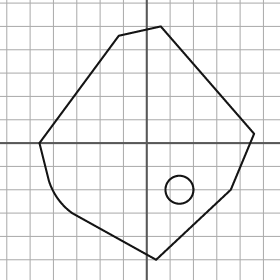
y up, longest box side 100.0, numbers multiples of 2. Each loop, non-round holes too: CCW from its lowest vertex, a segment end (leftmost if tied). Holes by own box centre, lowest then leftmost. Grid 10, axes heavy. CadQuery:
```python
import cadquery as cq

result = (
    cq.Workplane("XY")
    .moveTo(4.0, -50.0)
    .lineTo(36.0, -20.0)
    .lineTo(46.0, 4.0)
    .lineTo(6.0, 50.0)
    .lineTo(-12.0, 46.0)
    .lineTo(-46.0, 0.0)
    .lineTo(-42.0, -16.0)
    .threePointArc((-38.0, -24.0), (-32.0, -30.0))
    .close()
    .moveTo(14.0, -20.0)
    .circle(6.0)
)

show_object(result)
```